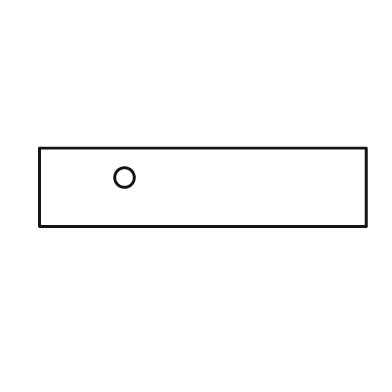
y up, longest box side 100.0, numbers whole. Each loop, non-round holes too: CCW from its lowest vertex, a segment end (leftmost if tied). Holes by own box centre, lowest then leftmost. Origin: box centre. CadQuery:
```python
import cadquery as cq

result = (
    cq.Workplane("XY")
    .moveTo(-50.0, -12.0)
    .lineTo(50.0, -12.0)
    .lineTo(50.0, 12.0)
    .lineTo(-50.0, 12.0)
    .close()
    .moveTo(-24.0, 3.0)
    .circle(3.0)
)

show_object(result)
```